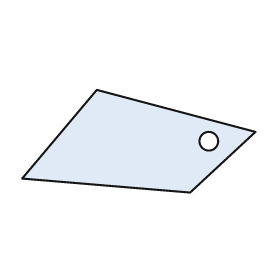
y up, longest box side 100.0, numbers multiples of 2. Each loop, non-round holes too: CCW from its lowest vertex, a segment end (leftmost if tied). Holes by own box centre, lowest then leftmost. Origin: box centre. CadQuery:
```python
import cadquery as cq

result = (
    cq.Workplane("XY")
    .moveTo(22.0, -22.0)
    .lineTo(50.0, 4.0)
    .lineTo(-18.0, 22.0)
    .lineTo(-50.0, -16.0)
    .close()
    .moveTo(30.0, 0.0)
    .circle(4.0)
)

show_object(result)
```